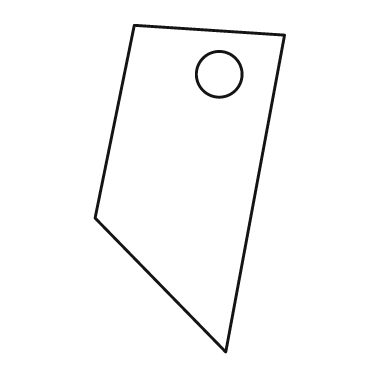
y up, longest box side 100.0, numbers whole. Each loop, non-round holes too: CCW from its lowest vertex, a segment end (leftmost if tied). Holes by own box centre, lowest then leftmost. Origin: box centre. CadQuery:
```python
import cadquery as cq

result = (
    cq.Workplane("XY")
    .moveTo(11.0, -50.0)
    .lineTo(29.0, 47.0)
    .lineTo(-17.0, 50.0)
    .lineTo(-29.0, -9.0)
    .close()
    .moveTo(9.0, 35.0)
    .circle(7.0)
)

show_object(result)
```